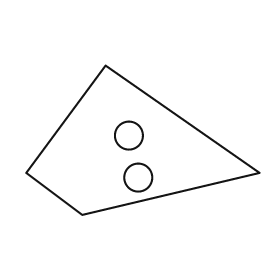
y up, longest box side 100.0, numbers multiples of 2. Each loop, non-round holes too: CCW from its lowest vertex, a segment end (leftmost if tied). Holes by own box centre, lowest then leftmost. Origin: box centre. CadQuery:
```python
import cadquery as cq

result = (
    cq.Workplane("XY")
    .moveTo(-26.0, -32.0)
    .lineTo(50.0, -14.0)
    .lineTo(-16.0, 32.0)
    .lineTo(-50.0, -14.0)
    .close()
    .moveTo(-2.0, -16.0)
    .circle(6.0)
    .moveTo(-6.0, 2.0)
    .circle(6.0)
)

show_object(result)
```